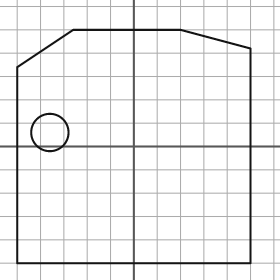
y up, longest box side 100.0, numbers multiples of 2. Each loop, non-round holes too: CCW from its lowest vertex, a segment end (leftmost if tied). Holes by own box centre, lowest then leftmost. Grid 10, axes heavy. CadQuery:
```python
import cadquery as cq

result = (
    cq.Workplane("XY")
    .moveTo(-50.0, -50.0)
    .lineTo(50.0, -50.0)
    .lineTo(50.0, 42.0)
    .lineTo(20.0, 50.0)
    .lineTo(-26.0, 50.0)
    .lineTo(-50.0, 34.0)
    .close()
    .moveTo(-36.0, 6.0)
    .circle(8.0)
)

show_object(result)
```